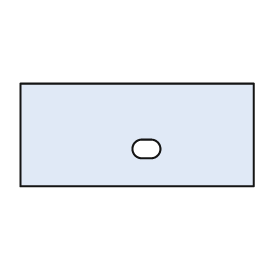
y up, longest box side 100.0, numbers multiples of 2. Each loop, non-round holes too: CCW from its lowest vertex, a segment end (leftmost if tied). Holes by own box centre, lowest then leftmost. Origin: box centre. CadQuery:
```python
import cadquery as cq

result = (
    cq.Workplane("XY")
    .moveTo(-50.0, -22.0)
    .lineTo(50.0, -22.0)
    .lineTo(50.0, 22.0)
    .lineTo(-50.0, 22.0)
    .close()
    .moveTo(2.0, -10.0)
    .lineTo(6.0, -10.0)
    .threePointArc((10.0, -6.0), (6.0, -2.0))
    .lineTo(2.0, -2.0)
    .threePointArc((-2.0, -6.0), (2.0, -10.0))
    .close()
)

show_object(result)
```